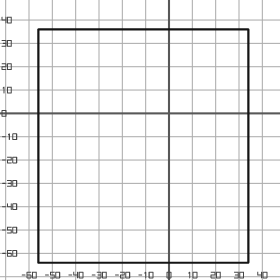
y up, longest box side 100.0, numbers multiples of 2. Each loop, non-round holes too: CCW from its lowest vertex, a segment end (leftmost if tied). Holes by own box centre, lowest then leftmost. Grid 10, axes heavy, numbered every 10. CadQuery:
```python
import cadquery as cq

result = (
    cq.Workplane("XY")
    .moveTo(-56.0, -64.0)
    .lineTo(34.0, -64.0)
    .lineTo(34.0, 36.0)
    .lineTo(-56.0, 36.0)
    .close()
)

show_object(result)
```